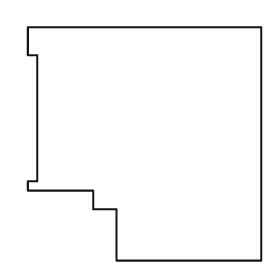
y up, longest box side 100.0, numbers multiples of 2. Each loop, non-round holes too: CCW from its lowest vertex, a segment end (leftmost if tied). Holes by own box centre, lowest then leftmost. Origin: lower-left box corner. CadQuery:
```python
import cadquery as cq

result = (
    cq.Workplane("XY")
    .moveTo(38.0, 0.0)
    .lineTo(100.0, 0.0)
    .lineTo(100.0, 100.0)
    .lineTo(0.0, 100.0)
    .lineTo(0.0, 88.0)
    .lineTo(4.0, 88.0)
    .lineTo(4.0, 34.0)
    .lineTo(0.0, 34.0)
    .lineTo(0.0, 30.0)
    .lineTo(28.0, 30.0)
    .lineTo(28.0, 22.0)
    .lineTo(38.0, 22.0)
    .close()
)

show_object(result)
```